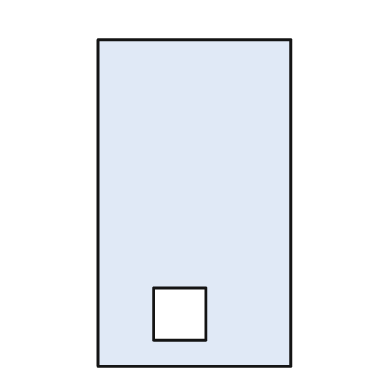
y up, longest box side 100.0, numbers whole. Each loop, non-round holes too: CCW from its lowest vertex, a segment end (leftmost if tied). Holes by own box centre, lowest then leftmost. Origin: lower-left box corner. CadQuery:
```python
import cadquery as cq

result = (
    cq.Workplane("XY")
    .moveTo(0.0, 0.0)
    .lineTo(59.0, 0.0)
    .lineTo(59.0, 100.0)
    .lineTo(0.0, 100.0)
    .close()
    .moveTo(17.0, 8.0)
    .lineTo(33.0, 8.0)
    .lineTo(33.0, 24.0)
    .lineTo(17.0, 24.0)
    .close()
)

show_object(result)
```